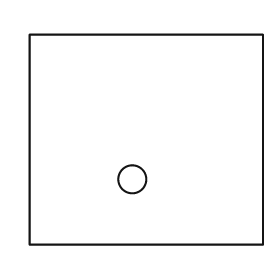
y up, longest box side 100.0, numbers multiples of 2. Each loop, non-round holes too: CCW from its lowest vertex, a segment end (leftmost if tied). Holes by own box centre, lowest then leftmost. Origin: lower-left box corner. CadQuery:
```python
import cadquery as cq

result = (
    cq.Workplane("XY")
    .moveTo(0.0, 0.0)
    .lineTo(100.0, 0.0)
    .lineTo(100.0, 90.0)
    .lineTo(0.0, 90.0)
    .close()
    .moveTo(44.0, 28.0)
    .circle(6.0)
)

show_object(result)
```